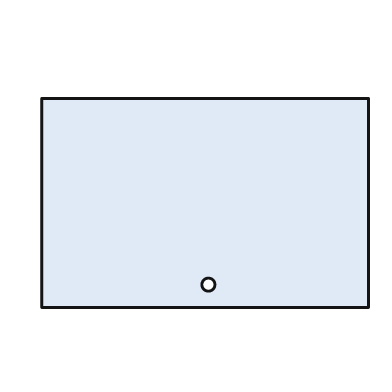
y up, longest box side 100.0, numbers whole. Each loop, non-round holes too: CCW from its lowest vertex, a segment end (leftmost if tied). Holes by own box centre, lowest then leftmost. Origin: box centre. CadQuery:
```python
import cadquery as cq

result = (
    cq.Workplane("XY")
    .moveTo(-50.0, -32.0)
    .lineTo(50.0, -32.0)
    .lineTo(50.0, 32.0)
    .lineTo(-50.0, 32.0)
    .close()
    .moveTo(1.0, -25.0)
    .circle(2.0)
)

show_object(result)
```